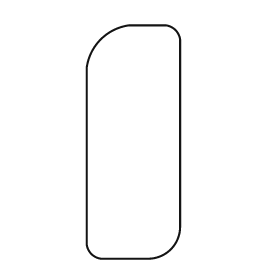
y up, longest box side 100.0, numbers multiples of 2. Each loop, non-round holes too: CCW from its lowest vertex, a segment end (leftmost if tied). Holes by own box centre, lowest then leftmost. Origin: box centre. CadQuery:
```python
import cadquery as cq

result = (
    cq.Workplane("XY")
    .moveTo(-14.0, -50.0)
    .lineTo(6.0, -50.0)
    .threePointArc((16.0, -46.0), (20.0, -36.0))
    .lineTo(20.0, 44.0)
    .threePointArc((18.0, 48.0), (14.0, 50.0))
    .lineTo(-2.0, 50.0)
    .threePointArc((-14.0, 44.0), (-20.0, 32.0))
    .lineTo(-20.0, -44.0)
    .threePointArc((-18.0, -48.0), (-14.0, -50.0))
    .close()
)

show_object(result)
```